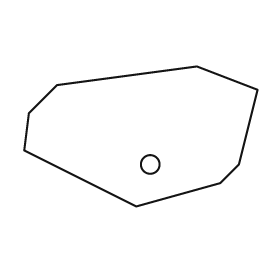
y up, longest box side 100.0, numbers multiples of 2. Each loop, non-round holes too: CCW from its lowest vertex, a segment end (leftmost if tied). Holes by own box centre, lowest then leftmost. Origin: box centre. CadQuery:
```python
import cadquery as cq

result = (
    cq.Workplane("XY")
    .moveTo(-2.0, -30.0)
    .lineTo(34.0, -20.0)
    .lineTo(42.0, -12.0)
    .lineTo(50.0, 20.0)
    .lineTo(24.0, 30.0)
    .lineTo(-36.0, 22.0)
    .lineTo(-48.0, 10.0)
    .lineTo(-50.0, -6.0)
    .close()
    .moveTo(4.0, -12.0)
    .circle(4.0)
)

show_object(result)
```